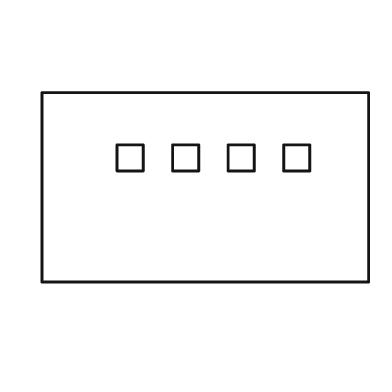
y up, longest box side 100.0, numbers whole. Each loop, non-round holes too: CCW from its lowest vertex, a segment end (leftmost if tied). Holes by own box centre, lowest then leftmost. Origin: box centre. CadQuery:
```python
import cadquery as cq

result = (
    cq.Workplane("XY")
    .moveTo(-50.0, -29.0)
    .lineTo(50.0, -29.0)
    .lineTo(50.0, 29.0)
    .lineTo(-50.0, 29.0)
    .close()
    .moveTo(-27.0, 5.0)
    .lineTo(-19.0, 5.0)
    .lineTo(-19.0, 13.0)
    .lineTo(-27.0, 13.0)
    .close()
    .moveTo(-10.0, 5.0)
    .lineTo(-2.0, 5.0)
    .lineTo(-2.0, 13.0)
    .lineTo(-10.0, 13.0)
    .close()
    .moveTo(7.0, 5.0)
    .lineTo(15.0, 5.0)
    .lineTo(15.0, 13.0)
    .lineTo(7.0, 13.0)
    .close()
    .moveTo(24.0, 5.0)
    .lineTo(32.0, 5.0)
    .lineTo(32.0, 13.0)
    .lineTo(24.0, 13.0)
    .close()
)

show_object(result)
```